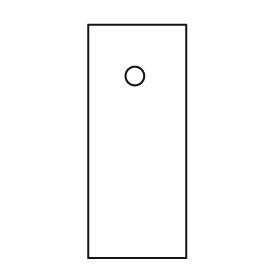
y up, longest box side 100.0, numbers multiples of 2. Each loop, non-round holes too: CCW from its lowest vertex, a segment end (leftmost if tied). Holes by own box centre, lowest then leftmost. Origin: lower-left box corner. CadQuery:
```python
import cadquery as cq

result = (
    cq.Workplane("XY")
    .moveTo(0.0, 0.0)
    .lineTo(42.0, 0.0)
    .lineTo(42.0, 100.0)
    .lineTo(0.0, 100.0)
    .close()
    .moveTo(20.0, 78.0)
    .circle(4.0)
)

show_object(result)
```